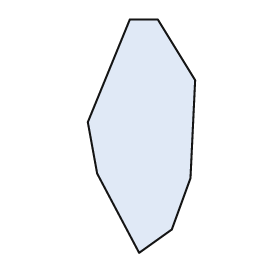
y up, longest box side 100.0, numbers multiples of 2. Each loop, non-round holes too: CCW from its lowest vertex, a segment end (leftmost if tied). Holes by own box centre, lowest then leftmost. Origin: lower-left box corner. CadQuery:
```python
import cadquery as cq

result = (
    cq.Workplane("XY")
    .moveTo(22.0, 0.0)
    .lineTo(36.0, 10.0)
    .lineTo(44.0, 32.0)
    .lineTo(46.0, 74.0)
    .lineTo(30.0, 100.0)
    .lineTo(18.0, 100.0)
    .lineTo(0.0, 56.0)
    .lineTo(4.0, 34.0)
    .close()
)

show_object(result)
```